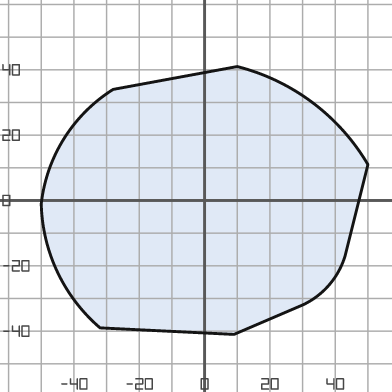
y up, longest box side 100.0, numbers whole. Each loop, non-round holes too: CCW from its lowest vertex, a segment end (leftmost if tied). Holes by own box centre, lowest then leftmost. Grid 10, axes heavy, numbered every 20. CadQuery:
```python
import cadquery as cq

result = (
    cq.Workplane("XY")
    .moveTo(9.0, -41.0)
    .lineTo(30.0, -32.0)
    .threePointArc((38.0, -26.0), (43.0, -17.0))
    .lineTo(50.0, 11.0)
    .threePointArc((33.0, 30.0), (10.0, 41.0))
    .lineTo(-28.0, 34.0)
    .threePointArc((-43.0, 19.0), (-50.0, -1.0))
    .threePointArc((-45.0, -22.0), (-32.0, -39.0))
    .close()
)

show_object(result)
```